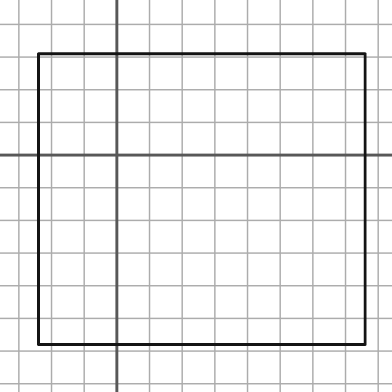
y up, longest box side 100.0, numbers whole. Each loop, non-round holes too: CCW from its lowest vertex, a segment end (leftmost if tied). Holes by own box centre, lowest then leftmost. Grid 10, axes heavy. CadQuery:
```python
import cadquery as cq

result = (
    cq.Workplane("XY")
    .moveTo(-24.0, -58.0)
    .lineTo(76.0, -58.0)
    .lineTo(76.0, 31.0)
    .lineTo(-24.0, 31.0)
    .close()
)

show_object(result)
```